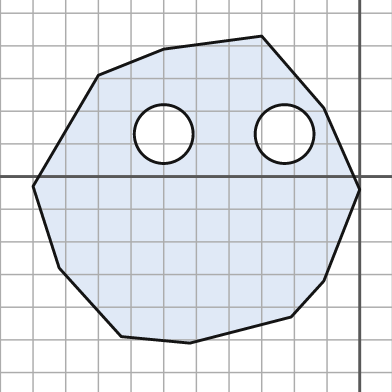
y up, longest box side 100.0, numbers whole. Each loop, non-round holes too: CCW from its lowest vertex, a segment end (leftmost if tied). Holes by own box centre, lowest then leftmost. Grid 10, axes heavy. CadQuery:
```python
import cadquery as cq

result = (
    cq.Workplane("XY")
    .moveTo(-52.0, -51.0)
    .lineTo(-21.0, -43.0)
    .lineTo(-11.0, -32.0)
    .lineTo(0.0, -4.0)
    .lineTo(-11.0, 21.0)
    .lineTo(-30.0, 43.0)
    .lineTo(-60.0, 39.0)
    .lineTo(-80.0, 31.0)
    .lineTo(-100.0, -3.0)
    .lineTo(-92.0, -28.0)
    .lineTo(-73.0, -49.0)
    .close()
    .moveTo(-60.0, 13.0)
    .circle(9.0)
    .moveTo(-23.0, 13.0)
    .circle(9.0)
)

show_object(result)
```